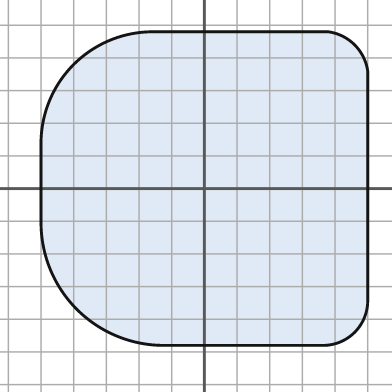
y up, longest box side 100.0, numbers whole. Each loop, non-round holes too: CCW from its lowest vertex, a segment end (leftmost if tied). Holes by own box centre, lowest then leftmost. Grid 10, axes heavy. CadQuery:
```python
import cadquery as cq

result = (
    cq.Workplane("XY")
    .moveTo(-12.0, -48.0)
    .lineTo(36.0, -48.0)
    .threePointArc((46.0, -44.0), (50.0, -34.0))
    .lineTo(50.0, 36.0)
    .threePointArc((46.0, 44.0), (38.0, 48.0))
    .lineTo(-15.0, 48.0)
    .threePointArc((-40.0, 38.0), (-50.0, 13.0))
    .lineTo(-50.0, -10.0)
    .threePointArc((-39.0, -37.0), (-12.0, -48.0))
    .close()
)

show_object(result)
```